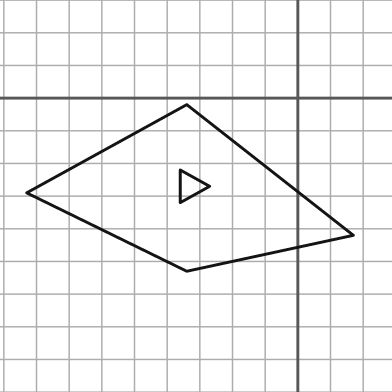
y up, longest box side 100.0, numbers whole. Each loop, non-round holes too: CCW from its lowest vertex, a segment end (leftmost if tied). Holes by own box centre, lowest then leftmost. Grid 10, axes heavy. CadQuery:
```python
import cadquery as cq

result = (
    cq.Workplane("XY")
    .moveTo(-34.0, -53.0)
    .lineTo(17.0, -42.0)
    .lineTo(-34.0, -2.0)
    .lineTo(-83.0, -29.0)
    .close()
    .moveTo(-36.0, -32.0)
    .lineTo(-27.0, -27.0)
    .lineTo(-36.0, -22.0)
    .close()
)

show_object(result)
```